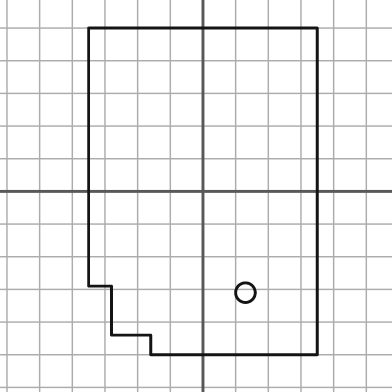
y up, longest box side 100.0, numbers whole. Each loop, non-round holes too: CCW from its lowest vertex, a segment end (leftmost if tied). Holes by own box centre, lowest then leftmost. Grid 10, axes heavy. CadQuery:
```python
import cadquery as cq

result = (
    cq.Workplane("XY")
    .moveTo(-16.0, -50.0)
    .lineTo(35.0, -50.0)
    .lineTo(35.0, 50.0)
    .lineTo(-35.0, 50.0)
    .lineTo(-35.0, -29.0)
    .lineTo(-28.0, -29.0)
    .lineTo(-28.0, -44.0)
    .lineTo(-16.0, -44.0)
    .close()
    .moveTo(13.0, -31.0)
    .circle(3.0)
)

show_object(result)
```